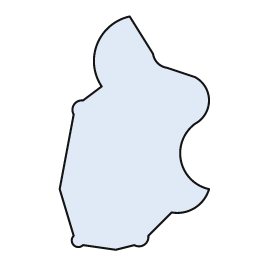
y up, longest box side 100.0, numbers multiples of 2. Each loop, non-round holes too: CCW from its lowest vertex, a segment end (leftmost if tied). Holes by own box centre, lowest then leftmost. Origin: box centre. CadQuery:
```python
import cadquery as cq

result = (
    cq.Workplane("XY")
    .moveTo(-8.0, -50.0)
    .lineTo(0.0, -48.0)
    .threePointArc((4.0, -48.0), (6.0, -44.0))
    .lineTo(16.0, -34.0)
    .threePointArc((26.0, -32.0), (32.0, -24.0))
    .threePointArc((20.0, -12.0), (26.0, 4.0))
    .threePointArc((32.0, 14.0), (26.0, 24.0))
    .lineTo(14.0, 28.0)
    .threePointArc((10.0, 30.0), (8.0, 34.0))
    .lineTo(-2.0, 50.0)
    .threePointArc((-16.0, 38.0), (-14.0, 20.0))
    .lineTo(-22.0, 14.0)
    .threePointArc((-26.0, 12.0), (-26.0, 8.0))
    .lineTo(-32.0, -24.0)
    .lineTo(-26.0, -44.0)
    .threePointArc((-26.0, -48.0), (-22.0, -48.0))
    .close()
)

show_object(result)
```